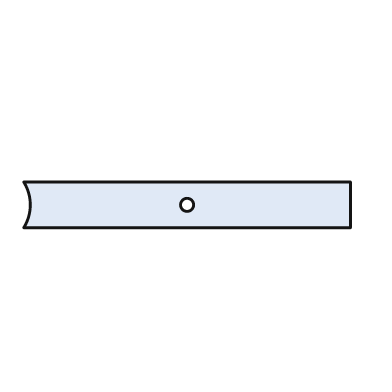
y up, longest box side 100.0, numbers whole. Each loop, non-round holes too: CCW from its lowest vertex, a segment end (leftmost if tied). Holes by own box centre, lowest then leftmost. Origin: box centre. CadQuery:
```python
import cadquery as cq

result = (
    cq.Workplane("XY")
    .moveTo(-50.0, -7.0)
    .lineTo(50.0, -7.0)
    .lineTo(50.0, 7.0)
    .lineTo(-50.0, 7.0)
    .threePointArc((-48.0, 0.0), (-50.0, -7.0))
    .close()
    .moveTo(0.0, 0.0)
    .circle(2.0)
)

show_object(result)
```